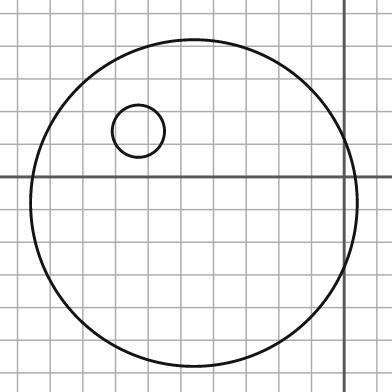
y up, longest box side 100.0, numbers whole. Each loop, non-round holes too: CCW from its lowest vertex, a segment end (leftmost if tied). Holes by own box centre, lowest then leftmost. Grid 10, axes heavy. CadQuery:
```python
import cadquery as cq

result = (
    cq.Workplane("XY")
    .moveTo(-46.0, -8.0)
    .circle(50.0)
    .moveTo(-63.0, 14.0)
    .circle(8.0)
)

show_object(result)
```